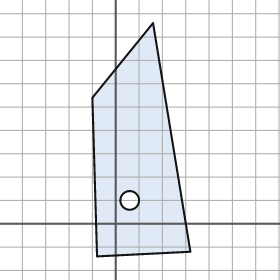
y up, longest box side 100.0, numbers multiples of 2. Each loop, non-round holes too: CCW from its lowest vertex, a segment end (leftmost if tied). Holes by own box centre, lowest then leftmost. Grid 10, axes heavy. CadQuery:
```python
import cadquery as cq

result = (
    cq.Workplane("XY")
    .moveTo(-8.0, -14.0)
    .lineTo(32.0, -12.0)
    .lineTo(16.0, 86.0)
    .lineTo(-10.0, 54.0)
    .close()
    .moveTo(6.0, 10.0)
    .circle(4.0)
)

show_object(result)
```